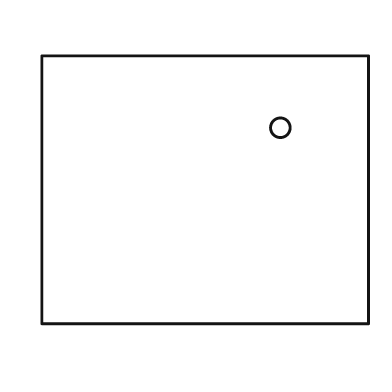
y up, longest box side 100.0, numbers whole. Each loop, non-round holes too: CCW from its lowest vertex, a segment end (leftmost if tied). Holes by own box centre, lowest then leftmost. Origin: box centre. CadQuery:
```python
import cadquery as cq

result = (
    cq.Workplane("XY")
    .moveTo(-50.0, -41.0)
    .lineTo(50.0, -41.0)
    .lineTo(50.0, 41.0)
    .lineTo(-50.0, 41.0)
    .close()
    .moveTo(23.0, 19.0)
    .circle(3.0)
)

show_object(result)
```